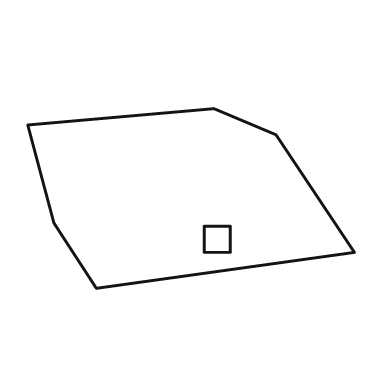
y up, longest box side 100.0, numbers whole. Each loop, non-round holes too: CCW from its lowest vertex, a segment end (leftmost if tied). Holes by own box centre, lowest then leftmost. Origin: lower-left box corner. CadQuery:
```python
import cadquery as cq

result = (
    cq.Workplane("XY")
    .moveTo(21.0, 0.0)
    .lineTo(100.0, 11.0)
    .lineTo(76.0, 47.0)
    .lineTo(57.0, 55.0)
    .lineTo(0.0, 50.0)
    .lineTo(8.0, 20.0)
    .close()
    .moveTo(54.0, 11.0)
    .lineTo(62.0, 11.0)
    .lineTo(62.0, 19.0)
    .lineTo(54.0, 19.0)
    .close()
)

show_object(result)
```